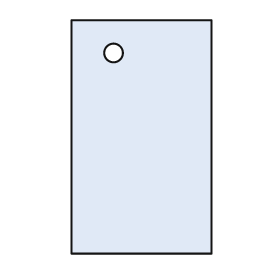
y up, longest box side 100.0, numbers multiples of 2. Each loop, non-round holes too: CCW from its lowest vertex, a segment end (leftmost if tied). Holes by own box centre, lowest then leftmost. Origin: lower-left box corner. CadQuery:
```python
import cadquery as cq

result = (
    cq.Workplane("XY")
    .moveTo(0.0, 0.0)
    .lineTo(60.0, 0.0)
    .lineTo(60.0, 100.0)
    .lineTo(0.0, 100.0)
    .close()
    .moveTo(18.0, 86.0)
    .circle(4.0)
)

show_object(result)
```